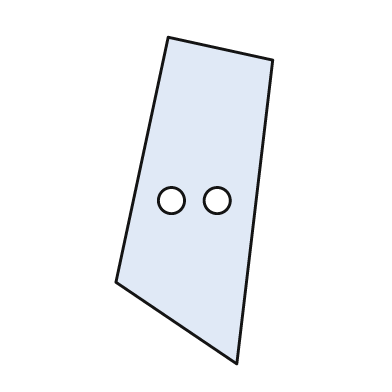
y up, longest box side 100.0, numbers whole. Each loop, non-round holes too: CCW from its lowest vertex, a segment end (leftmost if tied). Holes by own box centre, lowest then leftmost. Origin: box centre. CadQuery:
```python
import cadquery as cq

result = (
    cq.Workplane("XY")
    .moveTo(13.0, -50.0)
    .lineTo(24.0, 43.0)
    .lineTo(-8.0, 50.0)
    .lineTo(-24.0, -25.0)
    .close()
    .moveTo(-7.0, 0.0)
    .circle(4.0)
    .moveTo(7.0, 0.0)
    .circle(4.0)
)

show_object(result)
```